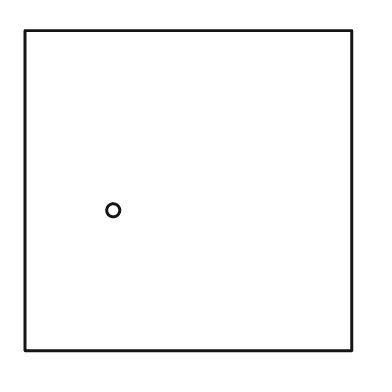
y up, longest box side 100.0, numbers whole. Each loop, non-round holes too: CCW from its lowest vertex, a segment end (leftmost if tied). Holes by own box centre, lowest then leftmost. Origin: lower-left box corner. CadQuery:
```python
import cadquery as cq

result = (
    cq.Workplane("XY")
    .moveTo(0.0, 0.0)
    .lineTo(100.0, 0.0)
    .lineTo(100.0, 98.0)
    .lineTo(0.0, 98.0)
    .close()
    .moveTo(27.0, 43.0)
    .circle(2.0)
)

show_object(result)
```